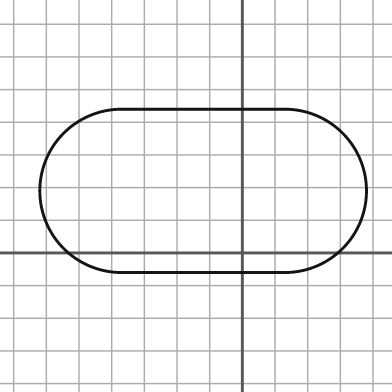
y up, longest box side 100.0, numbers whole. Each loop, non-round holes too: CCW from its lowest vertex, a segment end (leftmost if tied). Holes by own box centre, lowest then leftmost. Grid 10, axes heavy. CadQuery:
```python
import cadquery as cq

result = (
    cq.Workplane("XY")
    .moveTo(-37.0, -6.0)
    .lineTo(13.0, -6.0)
    .threePointArc((38.0, 19.0), (13.0, 44.0))
    .lineTo(-37.0, 44.0)
    .threePointArc((-62.0, 19.0), (-37.0, -6.0))
    .close()
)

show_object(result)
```